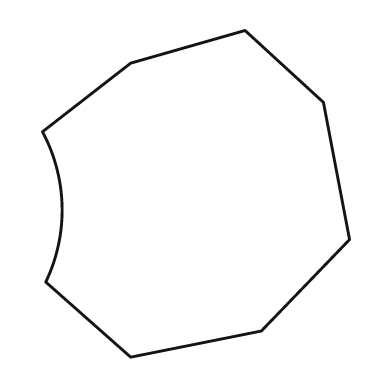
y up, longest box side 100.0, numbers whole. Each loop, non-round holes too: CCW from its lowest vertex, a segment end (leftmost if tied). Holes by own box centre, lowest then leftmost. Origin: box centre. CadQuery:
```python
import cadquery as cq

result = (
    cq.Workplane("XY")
    .moveTo(-20.0, -50.0)
    .lineTo(20.0, -42.0)
    .lineTo(47.0, -14.0)
    .lineTo(39.0, 28.0)
    .lineTo(15.0, 50.0)
    .lineTo(-20.0, 40.0)
    .lineTo(-47.0, 19.0)
    .threePointArc((-41.0, -4.0), (-46.0, -27.0))
    .close()
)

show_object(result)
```